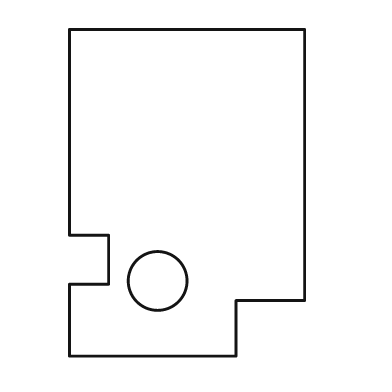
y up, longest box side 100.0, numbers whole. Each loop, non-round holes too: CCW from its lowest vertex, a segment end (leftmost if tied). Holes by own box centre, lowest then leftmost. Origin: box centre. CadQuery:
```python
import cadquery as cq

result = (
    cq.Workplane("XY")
    .moveTo(-36.0, -50.0)
    .lineTo(15.0, -50.0)
    .lineTo(15.0, -33.0)
    .lineTo(36.0, -33.0)
    .lineTo(36.0, 50.0)
    .lineTo(-36.0, 50.0)
    .lineTo(-36.0, -13.0)
    .lineTo(-24.0, -13.0)
    .lineTo(-24.0, -28.0)
    .lineTo(-36.0, -28.0)
    .close()
    .moveTo(-9.0, -27.0)
    .circle(9.0)
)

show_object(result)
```